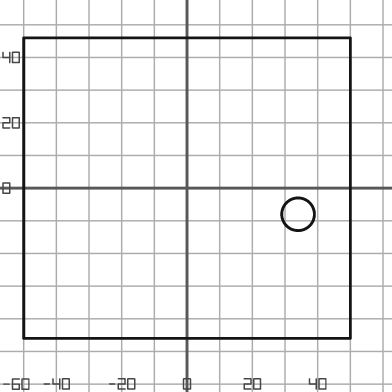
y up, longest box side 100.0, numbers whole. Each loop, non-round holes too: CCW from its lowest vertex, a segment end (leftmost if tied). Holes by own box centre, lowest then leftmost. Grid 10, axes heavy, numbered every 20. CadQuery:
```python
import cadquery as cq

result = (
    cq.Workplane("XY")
    .moveTo(-50.0, -46.0)
    .lineTo(50.0, -46.0)
    .lineTo(50.0, 46.0)
    .lineTo(-50.0, 46.0)
    .close()
    .moveTo(34.0, -8.0)
    .circle(5.0)
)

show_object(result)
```